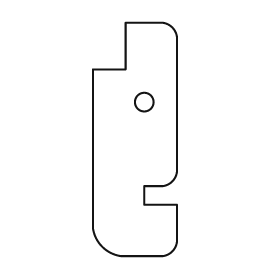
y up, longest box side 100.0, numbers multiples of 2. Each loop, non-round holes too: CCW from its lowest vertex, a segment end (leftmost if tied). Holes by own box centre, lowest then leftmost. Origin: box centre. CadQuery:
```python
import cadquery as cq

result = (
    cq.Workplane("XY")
    .moveTo(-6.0, -50.0)
    .lineTo(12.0, -50.0)
    .threePointArc((16.0, -48.0), (18.0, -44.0))
    .lineTo(18.0, -28.0)
    .lineTo(4.0, -28.0)
    .lineTo(4.0, -20.0)
    .lineTo(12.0, -20.0)
    .threePointArc((16.0, -18.0), (18.0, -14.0))
    .lineTo(18.0, 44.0)
    .threePointArc((16.0, 48.0), (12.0, 50.0))
    .lineTo(-4.0, 50.0)
    .lineTo(-4.0, 30.0)
    .lineTo(-18.0, 30.0)
    .lineTo(-18.0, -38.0)
    .threePointArc((-14.0, -46.0), (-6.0, -50.0))
    .close()
    .moveTo(4.0, 16.0)
    .circle(4.0)
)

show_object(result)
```